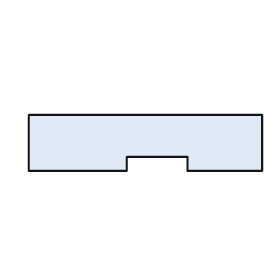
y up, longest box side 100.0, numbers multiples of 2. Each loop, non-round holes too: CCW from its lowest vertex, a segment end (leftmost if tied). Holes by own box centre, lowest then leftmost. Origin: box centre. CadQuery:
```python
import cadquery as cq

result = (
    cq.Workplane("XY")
    .moveTo(-50.0, -12.0)
    .lineTo(-8.0, -12.0)
    .lineTo(-8.0, -6.0)
    .lineTo(18.0, -6.0)
    .lineTo(18.0, -12.0)
    .lineTo(50.0, -12.0)
    .lineTo(50.0, 12.0)
    .lineTo(-50.0, 12.0)
    .close()
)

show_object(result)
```